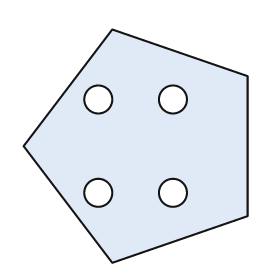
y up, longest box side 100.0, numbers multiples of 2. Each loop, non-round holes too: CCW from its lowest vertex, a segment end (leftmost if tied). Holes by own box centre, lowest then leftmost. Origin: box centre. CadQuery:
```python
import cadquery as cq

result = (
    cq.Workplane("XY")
    .moveTo(-10.0, -50.0)
    .lineTo(48.0, -30.0)
    .lineTo(48.0, 30.0)
    .lineTo(-10.0, 50.0)
    .lineTo(-48.0, 0.0)
    .close()
    .moveTo(-16.0, -20.0)
    .circle(6.0)
    .moveTo(16.0, -20.0)
    .circle(6.0)
    .moveTo(-16.0, 20.0)
    .circle(6.0)
    .moveTo(16.0, 20.0)
    .circle(6.0)
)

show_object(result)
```